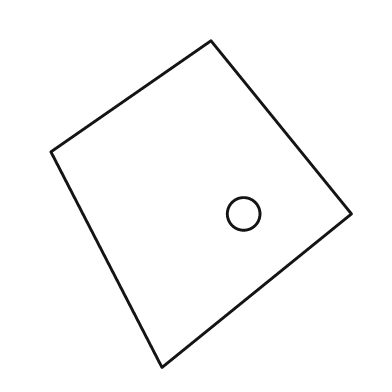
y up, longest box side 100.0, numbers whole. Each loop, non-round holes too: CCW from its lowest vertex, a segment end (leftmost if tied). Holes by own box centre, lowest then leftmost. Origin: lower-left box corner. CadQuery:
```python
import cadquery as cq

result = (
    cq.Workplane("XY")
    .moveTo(34.0, 0.0)
    .lineTo(92.0, 47.0)
    .lineTo(49.0, 100.0)
    .lineTo(0.0, 66.0)
    .close()
    .moveTo(59.0, 47.0)
    .circle(5.0)
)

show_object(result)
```